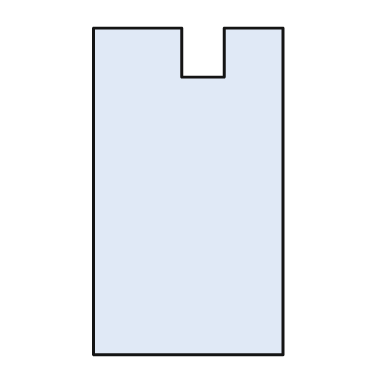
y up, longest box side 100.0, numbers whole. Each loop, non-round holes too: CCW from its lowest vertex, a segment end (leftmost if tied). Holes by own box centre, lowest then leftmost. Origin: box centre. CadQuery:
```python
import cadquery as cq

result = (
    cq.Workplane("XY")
    .moveTo(-29.0, -50.0)
    .lineTo(29.0, -50.0)
    .lineTo(29.0, 50.0)
    .lineTo(11.0, 50.0)
    .lineTo(11.0, 35.0)
    .lineTo(-2.0, 35.0)
    .lineTo(-2.0, 50.0)
    .lineTo(-29.0, 50.0)
    .close()
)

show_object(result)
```